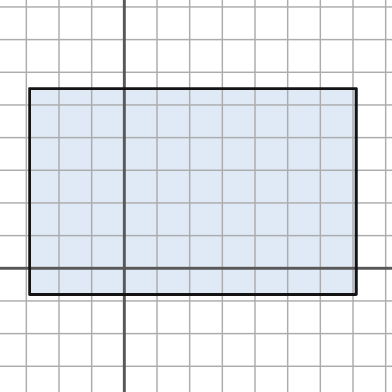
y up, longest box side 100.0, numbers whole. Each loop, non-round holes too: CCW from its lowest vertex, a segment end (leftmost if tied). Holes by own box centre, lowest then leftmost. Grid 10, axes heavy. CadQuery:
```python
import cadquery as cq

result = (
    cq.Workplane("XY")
    .moveTo(-29.0, -8.0)
    .lineTo(71.0, -8.0)
    .lineTo(71.0, 55.0)
    .lineTo(-29.0, 55.0)
    .close()
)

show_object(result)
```